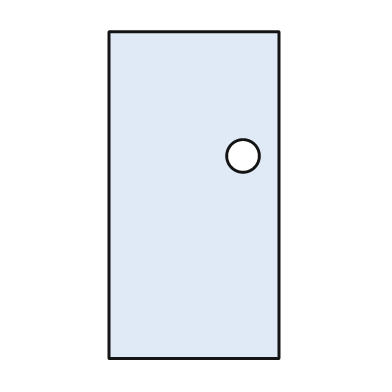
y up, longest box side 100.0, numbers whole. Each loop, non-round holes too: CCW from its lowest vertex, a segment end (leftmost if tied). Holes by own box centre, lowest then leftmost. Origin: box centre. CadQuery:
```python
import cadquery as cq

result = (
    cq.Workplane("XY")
    .moveTo(-26.0, -50.0)
    .lineTo(26.0, -50.0)
    .lineTo(26.0, 50.0)
    .lineTo(-26.0, 50.0)
    .close()
    .moveTo(15.0, 12.0)
    .circle(5.0)
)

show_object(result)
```